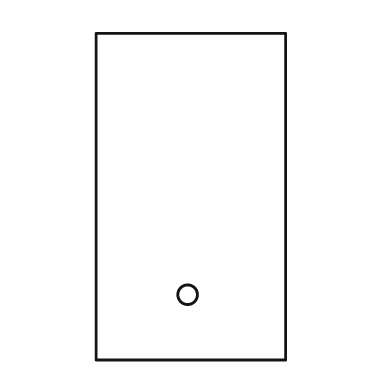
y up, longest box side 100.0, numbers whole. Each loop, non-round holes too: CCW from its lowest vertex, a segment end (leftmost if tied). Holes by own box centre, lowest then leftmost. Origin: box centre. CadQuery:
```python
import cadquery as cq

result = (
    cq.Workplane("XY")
    .moveTo(-29.0, -50.0)
    .lineTo(29.0, -50.0)
    .lineTo(29.0, 50.0)
    .lineTo(-29.0, 50.0)
    .close()
    .moveTo(-1.0, -30.0)
    .circle(3.0)
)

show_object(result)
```